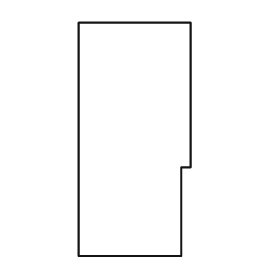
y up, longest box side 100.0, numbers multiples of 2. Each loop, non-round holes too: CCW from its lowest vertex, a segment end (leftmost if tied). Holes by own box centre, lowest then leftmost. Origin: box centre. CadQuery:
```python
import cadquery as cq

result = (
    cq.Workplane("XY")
    .moveTo(-24.0, -50.0)
    .lineTo(20.0, -50.0)
    .lineTo(20.0, -12.0)
    .lineTo(24.0, -12.0)
    .lineTo(24.0, 50.0)
    .lineTo(-24.0, 50.0)
    .close()
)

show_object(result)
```